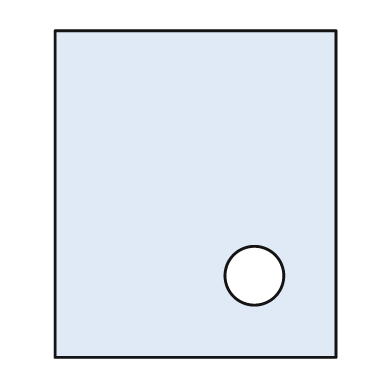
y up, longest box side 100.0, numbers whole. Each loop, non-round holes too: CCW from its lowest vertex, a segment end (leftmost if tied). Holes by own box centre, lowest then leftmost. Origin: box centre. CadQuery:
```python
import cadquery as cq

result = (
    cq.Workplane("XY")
    .moveTo(-43.0, -50.0)
    .lineTo(43.0, -50.0)
    .lineTo(43.0, 50.0)
    .lineTo(-43.0, 50.0)
    .close()
    .moveTo(18.0, -25.0)
    .circle(9.0)
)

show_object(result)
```